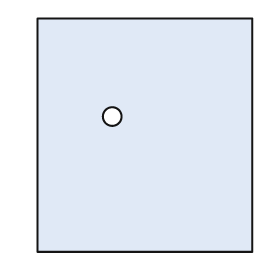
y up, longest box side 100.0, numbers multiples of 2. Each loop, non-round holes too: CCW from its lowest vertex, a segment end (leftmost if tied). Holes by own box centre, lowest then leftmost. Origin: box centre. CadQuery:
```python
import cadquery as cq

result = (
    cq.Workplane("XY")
    .moveTo(-46.0, -50.0)
    .lineTo(46.0, -50.0)
    .lineTo(46.0, 50.0)
    .lineTo(-46.0, 50.0)
    .close()
    .moveTo(-14.0, 8.0)
    .circle(4.0)
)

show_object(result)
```